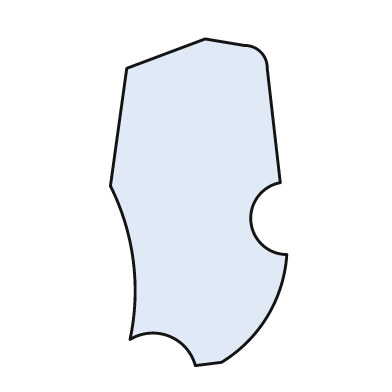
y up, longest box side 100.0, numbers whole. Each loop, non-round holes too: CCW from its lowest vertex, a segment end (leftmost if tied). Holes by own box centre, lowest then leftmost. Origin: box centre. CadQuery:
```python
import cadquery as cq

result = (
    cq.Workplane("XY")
    .moveTo(-1.0, -50.0)
    .lineTo(7.0, -49.0)
    .threePointArc((21.0, -35.0), (27.0, -16.0))
    .threePointArc((16.0, -6.0), (25.0, 6.0))
    .lineTo(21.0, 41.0)
    .threePointArc((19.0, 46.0), (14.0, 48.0))
    .lineTo(2.0, 50.0)
    .lineTo(-22.0, 41.0)
    .lineTo(-27.0, 5.0)
    .threePointArc((-20.0, -18.0), (-21.0, -42.0))
    .threePointArc((-9.0, -41.0), (-1.0, -50.0))
    .close()
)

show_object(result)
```